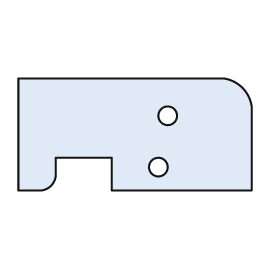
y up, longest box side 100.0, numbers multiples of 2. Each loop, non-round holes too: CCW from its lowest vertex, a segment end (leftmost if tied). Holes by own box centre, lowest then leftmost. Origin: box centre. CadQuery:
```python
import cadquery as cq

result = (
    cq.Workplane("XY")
    .moveTo(-50.0, -24.0)
    .lineTo(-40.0, -24.0)
    .threePointArc((-36.0, -22.0), (-34.0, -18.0))
    .lineTo(-34.0, -10.0)
    .lineTo(-10.0, -10.0)
    .lineTo(-10.0, -24.0)
    .lineTo(50.0, -24.0)
    .lineTo(50.0, 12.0)
    .threePointArc((46.0, 20.0), (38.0, 24.0))
    .lineTo(-50.0, 24.0)
    .close()
    .moveTo(10.0, -14.0)
    .circle(4.0)
    .moveTo(14.0, 8.0)
    .circle(4.0)
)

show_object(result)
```